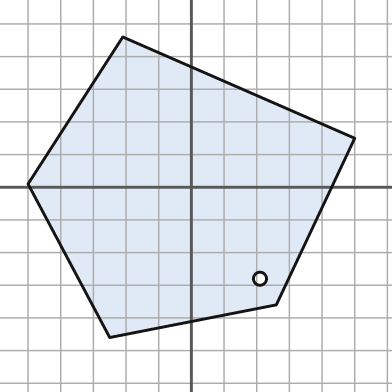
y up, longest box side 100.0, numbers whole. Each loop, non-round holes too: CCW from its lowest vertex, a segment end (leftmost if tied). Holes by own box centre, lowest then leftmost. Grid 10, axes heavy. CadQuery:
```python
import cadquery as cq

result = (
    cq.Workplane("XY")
    .moveTo(-25.0, -46.0)
    .lineTo(26.0, -36.0)
    .lineTo(50.0, 15.0)
    .lineTo(-21.0, 46.0)
    .lineTo(-50.0, 1.0)
    .close()
    .moveTo(21.0, -28.0)
    .circle(2.0)
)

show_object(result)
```